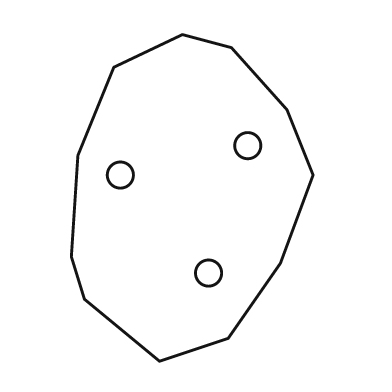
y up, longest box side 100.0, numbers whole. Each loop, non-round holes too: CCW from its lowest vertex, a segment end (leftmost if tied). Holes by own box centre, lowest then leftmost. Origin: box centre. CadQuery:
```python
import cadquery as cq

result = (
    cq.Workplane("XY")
    .moveTo(-10.0, -50.0)
    .lineTo(11.0, -43.0)
    .lineTo(27.0, -20.0)
    .lineTo(37.0, 7.0)
    .lineTo(29.0, 27.0)
    .lineTo(12.0, 46.0)
    .lineTo(-3.0, 50.0)
    .lineTo(-24.0, 40.0)
    .lineTo(-35.0, 13.0)
    .lineTo(-37.0, -18.0)
    .lineTo(-33.0, -31.0)
    .close()
    .moveTo(5.0, -23.0)
    .circle(4.0)
    .moveTo(-22.0, 7.0)
    .circle(4.0)
    .moveTo(17.0, 16.0)
    .circle(4.0)
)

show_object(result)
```